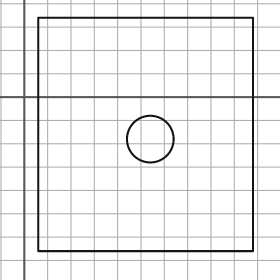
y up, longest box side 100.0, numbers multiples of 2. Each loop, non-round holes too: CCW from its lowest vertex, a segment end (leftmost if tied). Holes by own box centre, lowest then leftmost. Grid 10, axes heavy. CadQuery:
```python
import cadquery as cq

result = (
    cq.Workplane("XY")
    .moveTo(6.0, -66.0)
    .lineTo(98.0, -66.0)
    .lineTo(98.0, 34.0)
    .lineTo(6.0, 34.0)
    .close()
    .moveTo(54.0, -18.0)
    .circle(10.0)
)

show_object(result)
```